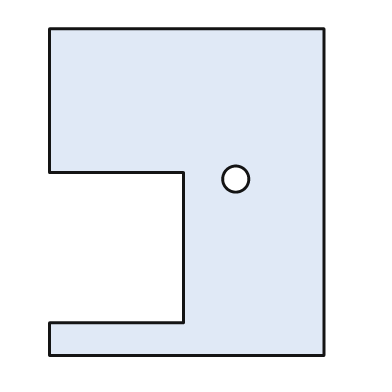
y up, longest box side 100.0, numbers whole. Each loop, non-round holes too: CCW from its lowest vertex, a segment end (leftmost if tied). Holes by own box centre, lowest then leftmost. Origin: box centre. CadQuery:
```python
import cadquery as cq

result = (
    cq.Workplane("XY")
    .moveTo(-42.0, -50.0)
    .lineTo(42.0, -50.0)
    .lineTo(42.0, 50.0)
    .lineTo(-42.0, 50.0)
    .lineTo(-42.0, 6.0)
    .lineTo(-1.0, 6.0)
    .lineTo(-1.0, -40.0)
    .lineTo(-42.0, -40.0)
    .close()
    .moveTo(15.0, 4.0)
    .circle(4.0)
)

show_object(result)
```